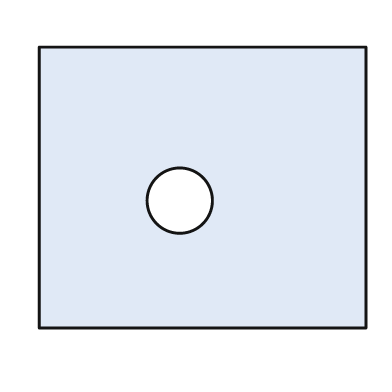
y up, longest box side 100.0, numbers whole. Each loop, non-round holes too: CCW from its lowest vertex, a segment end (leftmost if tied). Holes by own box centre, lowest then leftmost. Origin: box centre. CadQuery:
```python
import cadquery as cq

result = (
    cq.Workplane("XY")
    .moveTo(-50.0, -43.0)
    .lineTo(50.0, -43.0)
    .lineTo(50.0, 43.0)
    .lineTo(-50.0, 43.0)
    .close()
    .moveTo(-7.0, -4.0)
    .circle(10.0)
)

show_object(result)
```